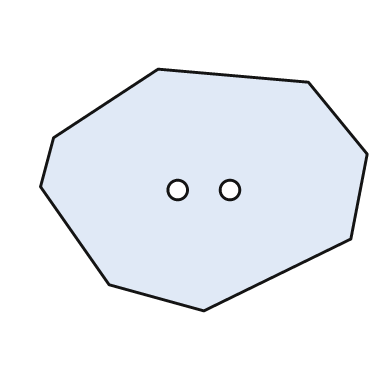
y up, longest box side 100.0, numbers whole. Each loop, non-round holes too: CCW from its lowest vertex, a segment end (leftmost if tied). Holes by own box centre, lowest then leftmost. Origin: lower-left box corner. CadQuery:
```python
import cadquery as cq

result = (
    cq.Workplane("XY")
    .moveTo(50.0, 0.0)
    .lineTo(95.0, 22.0)
    .lineTo(100.0, 48.0)
    .lineTo(82.0, 70.0)
    .lineTo(36.0, 74.0)
    .lineTo(4.0, 53.0)
    .lineTo(0.0, 38.0)
    .lineTo(21.0, 8.0)
    .close()
    .moveTo(42.0, 37.0)
    .circle(3.0)
    .moveTo(58.0, 37.0)
    .circle(3.0)
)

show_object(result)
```